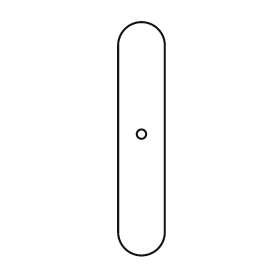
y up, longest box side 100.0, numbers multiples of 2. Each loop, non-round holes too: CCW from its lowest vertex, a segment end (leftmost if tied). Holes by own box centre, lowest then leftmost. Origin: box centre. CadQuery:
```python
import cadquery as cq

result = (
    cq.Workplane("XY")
    .moveTo(-10.0, -40.0)
    .threePointArc((0.0, -50.0), (10.0, -40.0))
    .lineTo(10.0, 40.0)
    .threePointArc((0.0, 50.0), (-10.0, 40.0))
    .close()
    .moveTo(0.0, 2.0)
    .circle(2.0)
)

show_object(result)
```